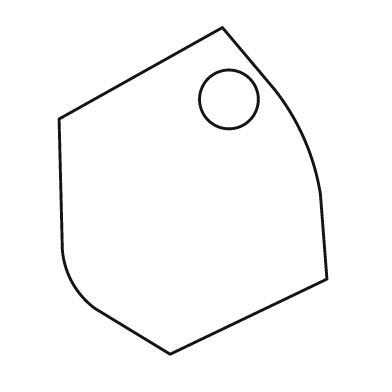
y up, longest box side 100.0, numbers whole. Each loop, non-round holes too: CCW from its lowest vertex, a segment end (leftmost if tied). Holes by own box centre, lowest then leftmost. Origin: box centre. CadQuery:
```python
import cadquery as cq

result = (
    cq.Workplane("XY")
    .moveTo(-7.0, -50.0)
    .lineTo(41.0, -27.0)
    .lineTo(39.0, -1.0)
    .threePointArc((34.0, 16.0), (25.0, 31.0))
    .lineTo(9.0, 50.0)
    .lineTo(-41.0, 22.0)
    .lineTo(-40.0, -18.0)
    .threePointArc((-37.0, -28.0), (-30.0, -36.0))
    .close()
    .moveTo(11.0, 28.0)
    .circle(9.0)
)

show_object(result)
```